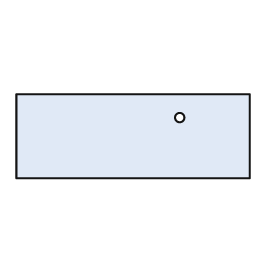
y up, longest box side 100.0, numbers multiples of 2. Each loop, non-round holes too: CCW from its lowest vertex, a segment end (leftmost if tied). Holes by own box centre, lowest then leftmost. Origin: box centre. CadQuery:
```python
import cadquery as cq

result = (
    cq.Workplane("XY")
    .moveTo(-50.0, -18.0)
    .lineTo(50.0, -18.0)
    .lineTo(50.0, 18.0)
    .lineTo(-50.0, 18.0)
    .close()
    .moveTo(20.0, 8.0)
    .circle(2.0)
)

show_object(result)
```